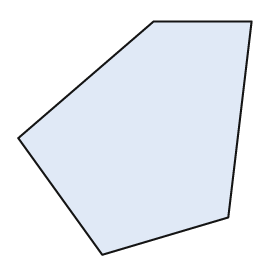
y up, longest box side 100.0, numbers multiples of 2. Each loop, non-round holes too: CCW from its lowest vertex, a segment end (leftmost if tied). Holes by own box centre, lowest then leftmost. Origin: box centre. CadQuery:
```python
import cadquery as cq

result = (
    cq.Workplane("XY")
    .moveTo(-14.0, -50.0)
    .lineTo(40.0, -34.0)
    .lineTo(50.0, 50.0)
    .lineTo(8.0, 50.0)
    .lineTo(-50.0, 0.0)
    .close()
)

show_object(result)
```